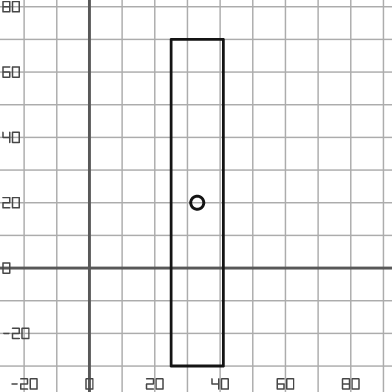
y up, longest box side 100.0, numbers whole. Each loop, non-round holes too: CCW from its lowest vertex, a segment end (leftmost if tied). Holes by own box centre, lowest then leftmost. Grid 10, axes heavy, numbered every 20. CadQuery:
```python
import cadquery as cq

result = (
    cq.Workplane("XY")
    .moveTo(25.0, -30.0)
    .lineTo(41.0, -30.0)
    .lineTo(41.0, 70.0)
    .lineTo(25.0, 70.0)
    .close()
    .moveTo(33.0, 20.0)
    .circle(2.0)
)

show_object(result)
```